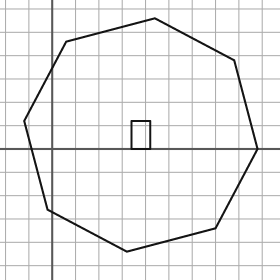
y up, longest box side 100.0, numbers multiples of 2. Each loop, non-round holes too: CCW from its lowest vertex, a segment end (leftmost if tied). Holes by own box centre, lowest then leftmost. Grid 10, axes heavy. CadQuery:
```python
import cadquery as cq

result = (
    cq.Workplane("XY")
    .moveTo(32.0, -44.0)
    .lineTo(70.0, -34.0)
    .lineTo(88.0, 0.0)
    .lineTo(78.0, 38.0)
    .lineTo(44.0, 56.0)
    .lineTo(6.0, 46.0)
    .lineTo(-12.0, 12.0)
    .lineTo(-2.0, -26.0)
    .close()
    .moveTo(34.0, 0.0)
    .lineTo(42.0, 0.0)
    .lineTo(42.0, 12.0)
    .lineTo(34.0, 12.0)
    .close()
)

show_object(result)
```